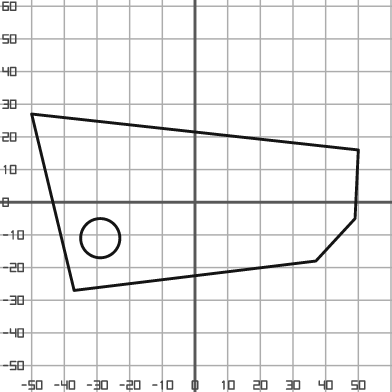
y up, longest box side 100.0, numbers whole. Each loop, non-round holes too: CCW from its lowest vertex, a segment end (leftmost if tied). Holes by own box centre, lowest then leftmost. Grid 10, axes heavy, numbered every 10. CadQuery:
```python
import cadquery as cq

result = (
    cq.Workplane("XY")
    .moveTo(-37.0, -27.0)
    .lineTo(37.0, -18.0)
    .lineTo(49.0, -5.0)
    .lineTo(50.0, 16.0)
    .lineTo(-50.0, 27.0)
    .close()
    .moveTo(-29.0, -11.0)
    .circle(6.0)
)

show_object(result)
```